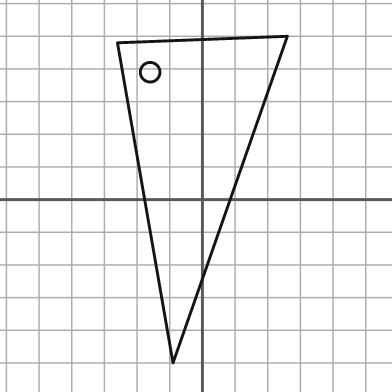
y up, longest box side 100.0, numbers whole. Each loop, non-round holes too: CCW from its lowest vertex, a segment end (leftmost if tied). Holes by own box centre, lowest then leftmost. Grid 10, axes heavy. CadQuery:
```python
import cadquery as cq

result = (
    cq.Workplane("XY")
    .moveTo(-9.0, -50.0)
    .lineTo(26.0, 50.0)
    .lineTo(-26.0, 48.0)
    .close()
    .moveTo(-16.0, 39.0)
    .circle(3.0)
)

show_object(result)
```